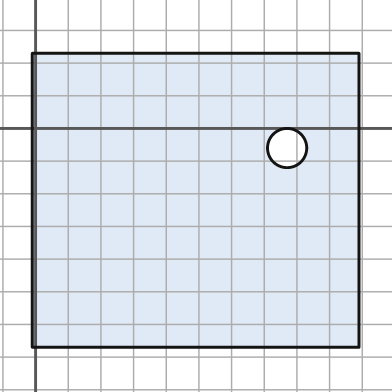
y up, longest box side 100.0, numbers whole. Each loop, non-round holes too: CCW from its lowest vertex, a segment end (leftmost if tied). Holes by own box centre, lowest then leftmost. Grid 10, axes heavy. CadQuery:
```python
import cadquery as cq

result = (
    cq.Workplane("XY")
    .moveTo(-1.0, -67.0)
    .lineTo(99.0, -67.0)
    .lineTo(99.0, 23.0)
    .lineTo(-1.0, 23.0)
    .close()
    .moveTo(77.0, -6.0)
    .circle(6.0)
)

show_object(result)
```